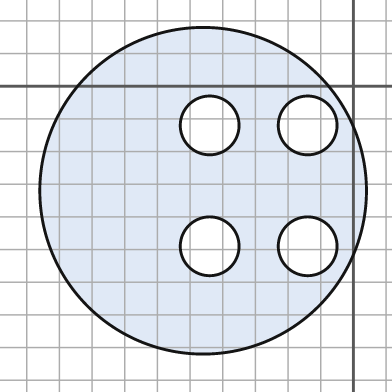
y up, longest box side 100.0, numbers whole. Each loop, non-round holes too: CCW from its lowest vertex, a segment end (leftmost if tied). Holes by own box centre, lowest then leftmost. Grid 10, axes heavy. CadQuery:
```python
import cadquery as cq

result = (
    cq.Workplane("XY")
    .moveTo(-46.0, -32.0)
    .circle(50.0)
    .moveTo(-44.0, -49.0)
    .circle(9.0)
    .moveTo(-14.0, -49.0)
    .circle(9.0)
    .moveTo(-44.0, -12.0)
    .circle(9.0)
    .moveTo(-14.0, -12.0)
    .circle(9.0)
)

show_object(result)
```